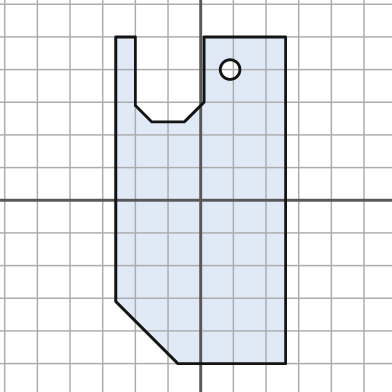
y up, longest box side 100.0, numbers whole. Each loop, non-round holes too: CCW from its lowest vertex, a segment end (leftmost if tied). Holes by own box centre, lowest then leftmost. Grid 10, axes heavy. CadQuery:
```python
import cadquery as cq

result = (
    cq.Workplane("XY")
    .moveTo(-7.0, -50.0)
    .lineTo(26.0, -50.0)
    .lineTo(26.0, 50.0)
    .lineTo(1.0, 50.0)
    .lineTo(1.0, 30.0)
    .lineTo(-5.0, 24.0)
    .lineTo(-15.0, 24.0)
    .lineTo(-20.0, 29.0)
    .lineTo(-20.0, 50.0)
    .lineTo(-26.0, 50.0)
    .lineTo(-26.0, -31.0)
    .close()
    .moveTo(9.0, 40.0)
    .circle(3.0)
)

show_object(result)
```